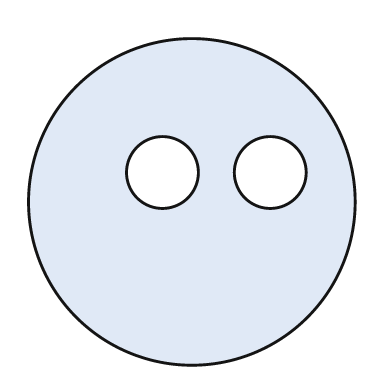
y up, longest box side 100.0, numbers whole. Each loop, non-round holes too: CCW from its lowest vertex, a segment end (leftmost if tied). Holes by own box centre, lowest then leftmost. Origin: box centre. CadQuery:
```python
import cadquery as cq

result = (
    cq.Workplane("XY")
    .moveTo(0.0, 0.0)
    .circle(50.0)
    .moveTo(-9.0, 9.0)
    .circle(11.0)
    .moveTo(24.0, 9.0)
    .circle(11.0)
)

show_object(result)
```